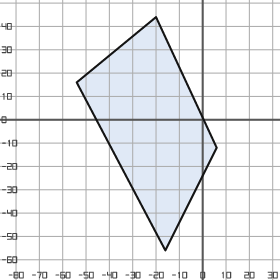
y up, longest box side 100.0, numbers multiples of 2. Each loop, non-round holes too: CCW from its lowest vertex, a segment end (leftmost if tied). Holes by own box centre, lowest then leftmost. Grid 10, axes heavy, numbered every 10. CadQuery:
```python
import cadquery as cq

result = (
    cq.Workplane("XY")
    .moveTo(-16.0, -56.0)
    .lineTo(6.0, -12.0)
    .lineTo(-20.0, 44.0)
    .lineTo(-54.0, 16.0)
    .close()
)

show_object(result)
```